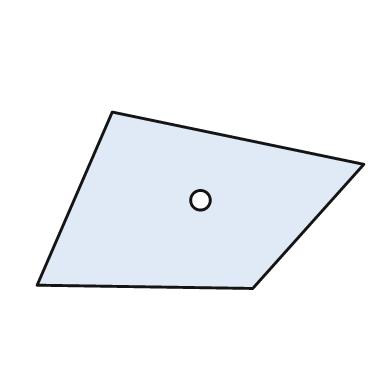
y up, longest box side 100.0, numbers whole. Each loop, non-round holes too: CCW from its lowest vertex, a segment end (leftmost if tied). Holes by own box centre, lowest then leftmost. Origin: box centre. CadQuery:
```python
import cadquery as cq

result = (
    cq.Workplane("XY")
    .moveTo(16.0, -27.0)
    .lineTo(50.0, 11.0)
    .lineTo(-27.0, 27.0)
    .lineTo(-50.0, -26.0)
    .close()
    .moveTo(0.0, 0.0)
    .circle(3.0)
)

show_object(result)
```